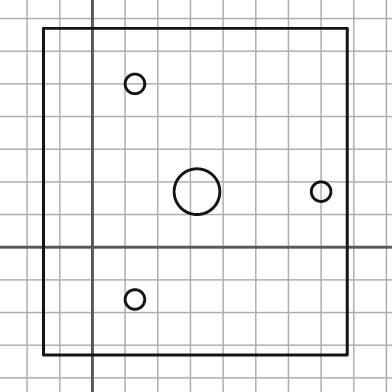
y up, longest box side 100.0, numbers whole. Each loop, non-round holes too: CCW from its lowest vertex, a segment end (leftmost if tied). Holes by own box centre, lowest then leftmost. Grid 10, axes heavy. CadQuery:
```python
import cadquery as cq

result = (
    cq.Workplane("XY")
    .moveTo(-15.0, -33.0)
    .lineTo(78.0, -33.0)
    .lineTo(78.0, 67.0)
    .lineTo(-15.0, 67.0)
    .close()
    .moveTo(13.0, -16.0)
    .circle(3.0)
    .moveTo(32.0, 17.0)
    .circle(7.0)
    .moveTo(70.0, 17.0)
    .circle(3.0)
    .moveTo(13.0, 50.0)
    .circle(3.0)
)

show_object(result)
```